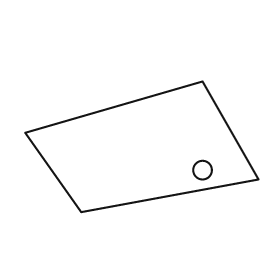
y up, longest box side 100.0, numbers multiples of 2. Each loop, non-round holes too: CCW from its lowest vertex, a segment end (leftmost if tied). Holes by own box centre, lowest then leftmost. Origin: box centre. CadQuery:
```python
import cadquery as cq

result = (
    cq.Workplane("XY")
    .moveTo(-26.0, -28.0)
    .lineTo(50.0, -14.0)
    .lineTo(26.0, 28.0)
    .lineTo(-50.0, 6.0)
    .close()
    .moveTo(26.0, -10.0)
    .circle(4.0)
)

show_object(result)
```